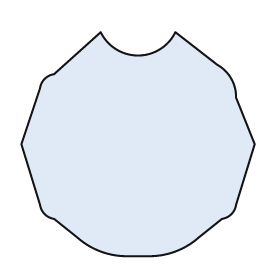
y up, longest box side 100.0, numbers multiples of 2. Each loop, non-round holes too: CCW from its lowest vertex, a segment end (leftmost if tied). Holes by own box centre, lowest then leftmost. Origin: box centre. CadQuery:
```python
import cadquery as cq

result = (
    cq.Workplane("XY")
    .moveTo(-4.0, -48.0)
    .lineTo(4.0, -48.0)
    .threePointArc((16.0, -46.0), (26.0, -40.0))
    .lineTo(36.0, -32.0)
    .threePointArc((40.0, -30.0), (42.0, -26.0))
    .lineTo(50.0, 0.0)
    .lineTo(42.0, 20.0)
    .threePointArc((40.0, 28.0), (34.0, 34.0))
    .lineTo(16.0, 48.0)
    .threePointArc((0.0, 38.0), (-16.0, 48.0))
    .lineTo(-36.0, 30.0)
    .threePointArc((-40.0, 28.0), (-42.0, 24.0))
    .lineTo(-50.0, 0.0)
    .lineTo(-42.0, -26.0)
    .threePointArc((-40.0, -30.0), (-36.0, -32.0))
    .lineTo(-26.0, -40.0)
    .threePointArc((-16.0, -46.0), (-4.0, -48.0))
    .close()
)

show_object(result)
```